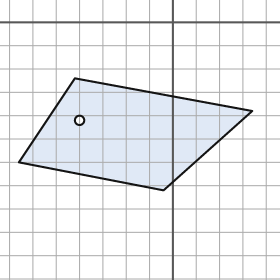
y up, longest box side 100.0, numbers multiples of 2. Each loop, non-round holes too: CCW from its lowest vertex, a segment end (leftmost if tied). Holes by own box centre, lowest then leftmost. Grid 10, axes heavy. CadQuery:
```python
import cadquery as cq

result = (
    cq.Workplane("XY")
    .moveTo(-4.0, -72.0)
    .lineTo(34.0, -38.0)
    .lineTo(-42.0, -24.0)
    .lineTo(-66.0, -60.0)
    .close()
    .moveTo(-40.0, -42.0)
    .circle(2.0)
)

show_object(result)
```